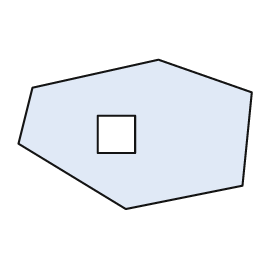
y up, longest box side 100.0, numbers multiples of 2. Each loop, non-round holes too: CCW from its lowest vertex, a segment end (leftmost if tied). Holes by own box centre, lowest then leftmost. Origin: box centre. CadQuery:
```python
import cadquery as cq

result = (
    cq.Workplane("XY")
    .moveTo(-4.0, -32.0)
    .lineTo(46.0, -22.0)
    .lineTo(50.0, 18.0)
    .lineTo(10.0, 32.0)
    .lineTo(-44.0, 20.0)
    .lineTo(-50.0, -4.0)
    .close()
    .moveTo(-16.0, -8.0)
    .lineTo(0.0, -8.0)
    .lineTo(0.0, 8.0)
    .lineTo(-16.0, 8.0)
    .close()
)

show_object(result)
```